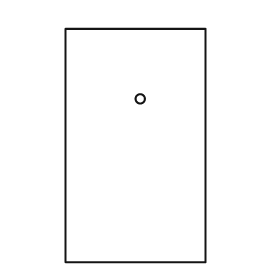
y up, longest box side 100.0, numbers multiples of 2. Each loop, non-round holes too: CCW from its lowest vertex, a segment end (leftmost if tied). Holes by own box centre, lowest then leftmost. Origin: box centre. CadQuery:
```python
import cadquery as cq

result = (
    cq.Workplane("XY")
    .moveTo(-30.0, -50.0)
    .lineTo(30.0, -50.0)
    .lineTo(30.0, 50.0)
    .lineTo(-30.0, 50.0)
    .close()
    .moveTo(2.0, 20.0)
    .circle(2.0)
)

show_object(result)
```